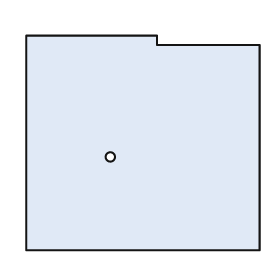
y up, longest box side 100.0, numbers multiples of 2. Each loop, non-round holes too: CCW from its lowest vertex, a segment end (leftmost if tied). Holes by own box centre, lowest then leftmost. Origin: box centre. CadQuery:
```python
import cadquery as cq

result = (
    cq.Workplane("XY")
    .moveTo(-50.0, -46.0)
    .lineTo(50.0, -46.0)
    .lineTo(50.0, 42.0)
    .lineTo(6.0, 42.0)
    .lineTo(6.0, 46.0)
    .lineTo(-50.0, 46.0)
    .close()
    .moveTo(-14.0, -6.0)
    .circle(2.0)
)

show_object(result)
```